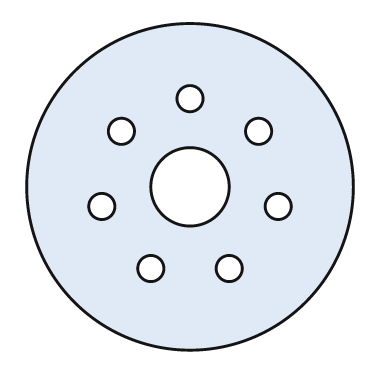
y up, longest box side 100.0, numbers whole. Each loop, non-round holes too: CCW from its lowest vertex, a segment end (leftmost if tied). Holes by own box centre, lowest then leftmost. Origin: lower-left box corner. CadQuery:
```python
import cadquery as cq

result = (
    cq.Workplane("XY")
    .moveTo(50.0, 50.0)
    .circle(50.0)
    .moveTo(38.0, 25.0)
    .circle(4.0)
    .moveTo(62.0, 25.0)
    .circle(4.0)
    .moveTo(23.0, 44.0)
    .circle(4.0)
    .moveTo(77.0, 44.0)
    .circle(4.0)
    .moveTo(50.0, 50.0)
    .circle(12.0)
    .moveTo(29.0, 67.0)
    .circle(4.0)
    .moveTo(71.0, 67.0)
    .circle(4.0)
    .moveTo(50.0, 77.0)
    .circle(4.0)
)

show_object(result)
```